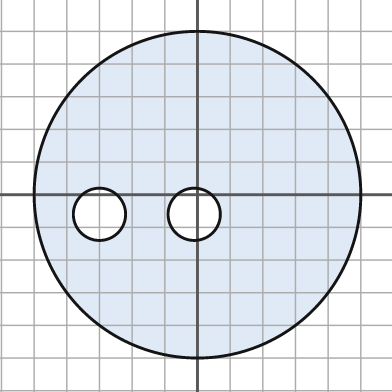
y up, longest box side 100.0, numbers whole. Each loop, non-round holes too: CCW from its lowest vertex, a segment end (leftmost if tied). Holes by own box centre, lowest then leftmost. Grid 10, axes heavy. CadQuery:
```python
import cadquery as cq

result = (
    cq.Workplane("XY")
    .moveTo(0.0, 0.0)
    .circle(50.0)
    .moveTo(-30.0, -6.0)
    .circle(8.0)
    .moveTo(-1.0, -6.0)
    .circle(8.0)
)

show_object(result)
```